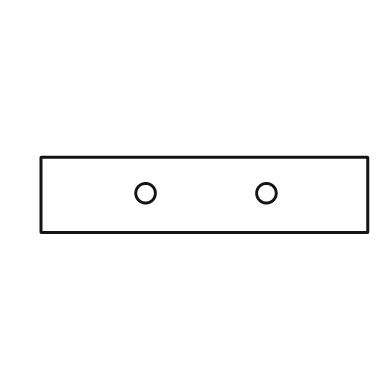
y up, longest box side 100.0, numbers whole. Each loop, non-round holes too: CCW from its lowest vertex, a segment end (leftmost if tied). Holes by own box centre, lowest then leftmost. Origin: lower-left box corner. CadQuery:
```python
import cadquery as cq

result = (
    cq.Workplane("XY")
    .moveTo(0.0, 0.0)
    .lineTo(100.0, 0.0)
    .lineTo(100.0, 23.0)
    .lineTo(0.0, 23.0)
    .close()
    .moveTo(32.0, 12.0)
    .circle(3.0)
    .moveTo(69.0, 12.0)
    .circle(3.0)
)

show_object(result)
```